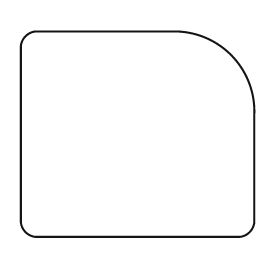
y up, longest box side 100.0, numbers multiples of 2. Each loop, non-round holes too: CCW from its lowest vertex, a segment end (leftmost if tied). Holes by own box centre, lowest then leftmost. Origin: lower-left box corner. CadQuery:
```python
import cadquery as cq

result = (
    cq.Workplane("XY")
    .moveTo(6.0, 0.0)
    .lineTo(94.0, 0.0)
    .threePointArc((98.0, 2.0), (100.0, 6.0))
    .lineTo(100.0, 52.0)
    .threePointArc((90.0, 78.0), (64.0, 88.0))
    .lineTo(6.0, 88.0)
    .threePointArc((2.0, 86.0), (0.0, 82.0))
    .lineTo(0.0, 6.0)
    .threePointArc((2.0, 2.0), (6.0, 0.0))
    .close()
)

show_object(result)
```